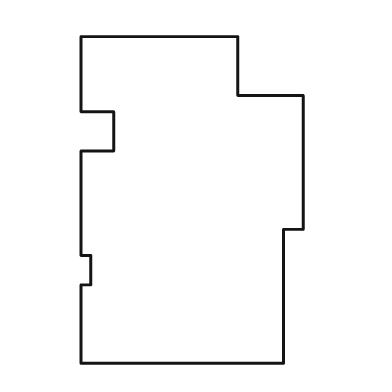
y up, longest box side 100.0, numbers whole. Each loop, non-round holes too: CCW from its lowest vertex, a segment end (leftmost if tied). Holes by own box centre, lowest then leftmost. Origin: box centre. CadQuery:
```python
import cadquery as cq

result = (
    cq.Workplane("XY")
    .moveTo(-34.0, -50.0)
    .lineTo(28.0, -50.0)
    .lineTo(28.0, -9.0)
    .lineTo(34.0, -9.0)
    .lineTo(34.0, 32.0)
    .lineTo(14.0, 32.0)
    .lineTo(14.0, 50.0)
    .lineTo(-34.0, 50.0)
    .lineTo(-34.0, 27.0)
    .lineTo(-24.0, 27.0)
    .lineTo(-24.0, 15.0)
    .lineTo(-34.0, 15.0)
    .lineTo(-34.0, -17.0)
    .lineTo(-31.0, -17.0)
    .lineTo(-31.0, -26.0)
    .lineTo(-34.0, -26.0)
    .close()
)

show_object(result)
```